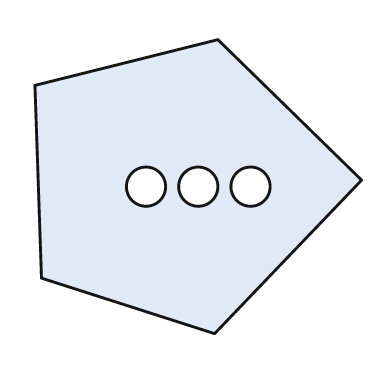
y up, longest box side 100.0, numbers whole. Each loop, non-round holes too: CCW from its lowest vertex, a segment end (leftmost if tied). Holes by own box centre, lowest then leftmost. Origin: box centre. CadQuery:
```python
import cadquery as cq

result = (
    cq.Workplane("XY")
    .moveTo(5.0, -45.0)
    .lineTo(50.0, 2.0)
    .lineTo(6.0, 45.0)
    .lineTo(-50.0, 31.0)
    .lineTo(-48.0, -28.0)
    .close()
    .moveTo(-16.0, 0.0)
    .circle(6.0)
    .moveTo(0.0, 0.0)
    .circle(6.0)
    .moveTo(16.0, 0.0)
    .circle(6.0)
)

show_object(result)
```